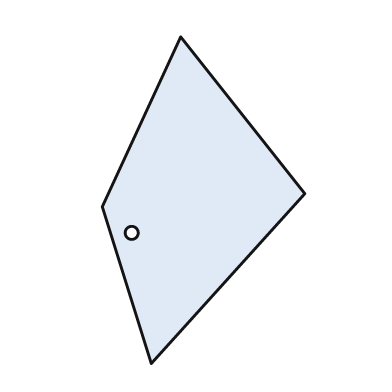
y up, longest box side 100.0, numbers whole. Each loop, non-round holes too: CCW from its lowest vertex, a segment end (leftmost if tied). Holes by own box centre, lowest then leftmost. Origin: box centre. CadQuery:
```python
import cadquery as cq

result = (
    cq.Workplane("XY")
    .moveTo(-16.0, -50.0)
    .lineTo(31.0, 2.0)
    .lineTo(-7.0, 50.0)
    .lineTo(-31.0, -2.0)
    .close()
    .moveTo(-22.0, -10.0)
    .circle(2.0)
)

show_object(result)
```